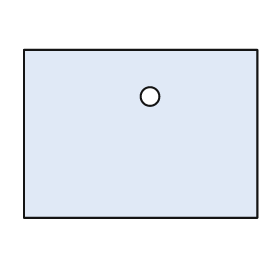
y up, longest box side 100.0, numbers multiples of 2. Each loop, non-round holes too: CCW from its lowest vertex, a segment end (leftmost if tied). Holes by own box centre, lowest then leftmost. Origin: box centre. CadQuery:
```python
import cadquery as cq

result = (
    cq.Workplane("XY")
    .moveTo(-50.0, -36.0)
    .lineTo(50.0, -36.0)
    .lineTo(50.0, 36.0)
    .lineTo(-50.0, 36.0)
    .close()
    .moveTo(4.0, 16.0)
    .circle(4.0)
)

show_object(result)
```